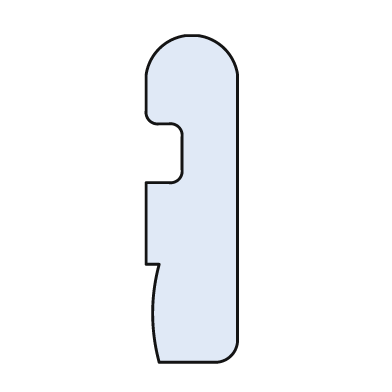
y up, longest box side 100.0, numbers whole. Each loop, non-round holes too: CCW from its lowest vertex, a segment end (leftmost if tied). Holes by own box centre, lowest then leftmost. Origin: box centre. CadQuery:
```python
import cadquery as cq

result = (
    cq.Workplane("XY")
    .moveTo(-10.0, -50.0)
    .lineTo(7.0, -50.0)
    .threePointArc((12.0, -48.0), (14.0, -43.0))
    .lineTo(14.0, 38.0)
    .threePointArc((10.0, 46.0), (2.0, 50.0))
    .lineTo(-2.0, 50.0)
    .threePointArc((-10.0, 46.0), (-14.0, 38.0))
    .lineTo(-14.0, 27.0)
    .threePointArc((-13.0, 24.0), (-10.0, 23.0))
    .lineTo(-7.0, 23.0)
    .threePointArc((-4.0, 22.0), (-3.0, 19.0))
    .lineTo(-3.0, 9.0)
    .threePointArc((-4.0, 6.0), (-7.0, 5.0))
    .lineTo(-14.0, 5.0)
    .lineTo(-14.0, -20.0)
    .lineTo(-10.0, -20.0)
    .threePointArc((-12.0, -35.0), (-10.0, -50.0))
    .close()
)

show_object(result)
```